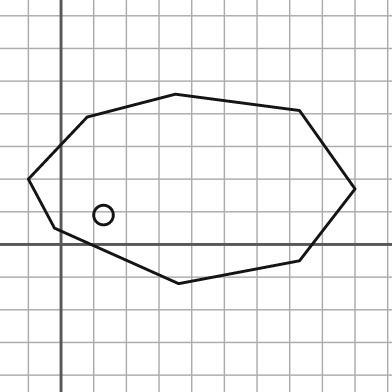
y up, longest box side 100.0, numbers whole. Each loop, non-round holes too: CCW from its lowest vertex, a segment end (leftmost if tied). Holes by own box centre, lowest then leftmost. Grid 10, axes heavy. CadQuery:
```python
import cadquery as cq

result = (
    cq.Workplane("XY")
    .moveTo(36.0, -12.0)
    .lineTo(73.0, -5.0)
    .lineTo(90.0, 17.0)
    .lineTo(73.0, 41.0)
    .lineTo(35.0, 46.0)
    .lineTo(8.0, 39.0)
    .lineTo(-10.0, 20.0)
    .lineTo(-2.0, 5.0)
    .close()
    .moveTo(13.0, 9.0)
    .circle(3.0)
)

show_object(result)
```